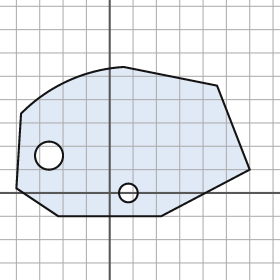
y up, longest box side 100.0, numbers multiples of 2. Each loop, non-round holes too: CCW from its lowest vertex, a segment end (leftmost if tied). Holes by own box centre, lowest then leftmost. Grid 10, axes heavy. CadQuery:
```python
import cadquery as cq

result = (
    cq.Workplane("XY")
    .moveTo(-22.0, -10.0)
    .lineTo(22.0, -10.0)
    .lineTo(60.0, 10.0)
    .lineTo(46.0, 46.0)
    .lineTo(6.0, 54.0)
    .threePointArc((-18.0, 48.0), (-38.0, 34.0))
    .lineTo(-40.0, 2.0)
    .close()
    .moveTo(8.0, 0.0)
    .circle(4.0)
    .moveTo(-26.0, 16.0)
    .circle(6.0)
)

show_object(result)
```